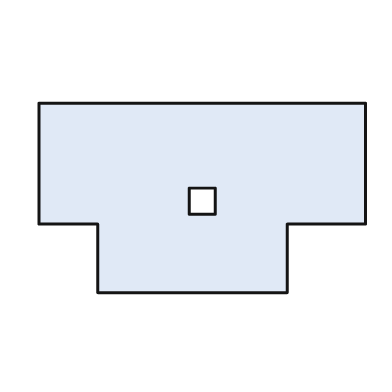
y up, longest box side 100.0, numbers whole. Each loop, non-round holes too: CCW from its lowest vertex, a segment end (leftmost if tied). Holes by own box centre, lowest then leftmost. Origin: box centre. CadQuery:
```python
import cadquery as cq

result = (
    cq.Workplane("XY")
    .moveTo(-32.0, -29.0)
    .lineTo(26.0, -29.0)
    .lineTo(26.0, -8.0)
    .lineTo(50.0, -8.0)
    .lineTo(50.0, 29.0)
    .lineTo(-50.0, 29.0)
    .lineTo(-50.0, -8.0)
    .lineTo(-32.0, -8.0)
    .close()
    .moveTo(-4.0, -5.0)
    .lineTo(4.0, -5.0)
    .lineTo(4.0, 3.0)
    .lineTo(-4.0, 3.0)
    .close()
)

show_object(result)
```